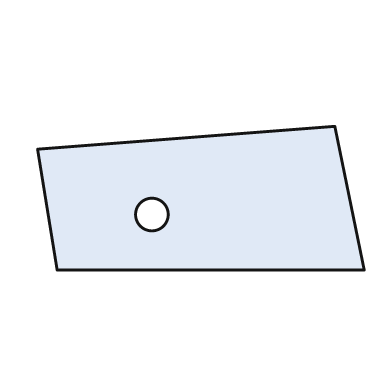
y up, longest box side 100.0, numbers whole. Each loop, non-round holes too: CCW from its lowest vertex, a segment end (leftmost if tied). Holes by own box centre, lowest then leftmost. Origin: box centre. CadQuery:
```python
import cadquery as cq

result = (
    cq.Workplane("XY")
    .moveTo(-44.0, -22.0)
    .lineTo(50.0, -22.0)
    .lineTo(41.0, 22.0)
    .lineTo(-50.0, 15.0)
    .close()
    .moveTo(-15.0, -5.0)
    .circle(5.0)
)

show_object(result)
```